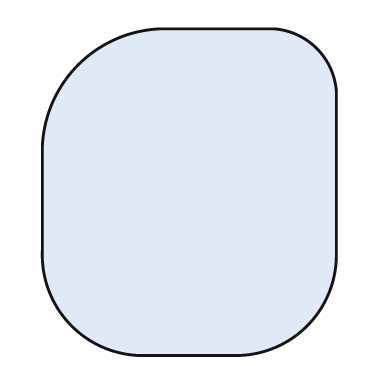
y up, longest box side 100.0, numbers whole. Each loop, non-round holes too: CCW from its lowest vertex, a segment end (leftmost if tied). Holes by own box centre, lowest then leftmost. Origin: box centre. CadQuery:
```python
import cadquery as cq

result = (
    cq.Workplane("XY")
    .moveTo(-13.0, -50.0)
    .lineTo(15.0, -50.0)
    .threePointArc((36.0, -41.0), (45.0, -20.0))
    .lineTo(45.0, 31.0)
    .threePointArc((39.0, 44.0), (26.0, 50.0))
    .lineTo(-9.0, 50.0)
    .threePointArc((-34.0, 39.0), (-45.0, 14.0))
    .lineTo(-45.0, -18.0)
    .threePointArc((-36.0, -41.0), (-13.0, -50.0))
    .close()
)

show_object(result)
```